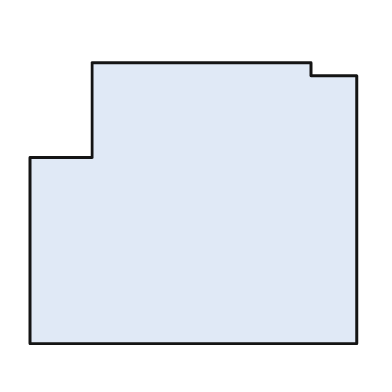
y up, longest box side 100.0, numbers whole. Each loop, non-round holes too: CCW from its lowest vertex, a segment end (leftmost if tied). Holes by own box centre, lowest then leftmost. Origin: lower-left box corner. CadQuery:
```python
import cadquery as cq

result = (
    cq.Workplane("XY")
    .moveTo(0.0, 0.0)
    .lineTo(100.0, 0.0)
    .lineTo(100.0, 82.0)
    .lineTo(86.0, 82.0)
    .lineTo(86.0, 86.0)
    .lineTo(19.0, 86.0)
    .lineTo(19.0, 57.0)
    .lineTo(0.0, 57.0)
    .close()
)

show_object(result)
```